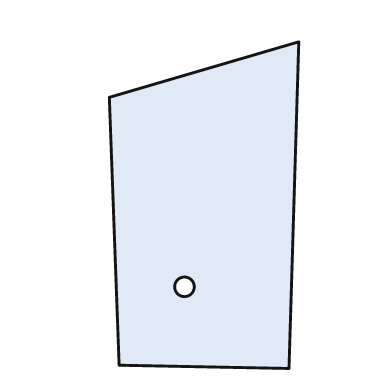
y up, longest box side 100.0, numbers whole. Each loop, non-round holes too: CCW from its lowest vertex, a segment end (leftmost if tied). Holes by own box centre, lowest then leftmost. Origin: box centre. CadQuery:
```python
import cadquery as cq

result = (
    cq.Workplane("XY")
    .moveTo(26.0, -50.0)
    .lineTo(29.0, 50.0)
    .lineTo(-29.0, 33.0)
    .lineTo(-26.0, -49.0)
    .close()
    .moveTo(-6.0, -25.0)
    .circle(3.0)
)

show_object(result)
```